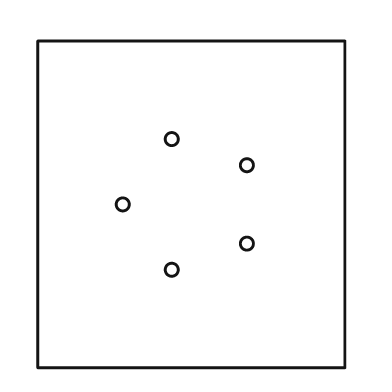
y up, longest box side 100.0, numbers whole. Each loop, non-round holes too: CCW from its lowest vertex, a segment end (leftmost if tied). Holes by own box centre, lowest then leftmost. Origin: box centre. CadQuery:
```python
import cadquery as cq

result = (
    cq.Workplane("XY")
    .moveTo(-47.0, -50.0)
    .lineTo(47.0, -50.0)
    .lineTo(47.0, 50.0)
    .lineTo(-47.0, 50.0)
    .close()
    .moveTo(-6.0, -20.0)
    .circle(2.0)
    .moveTo(17.0, -12.0)
    .circle(2.0)
    .moveTo(-21.0, 0.0)
    .circle(2.0)
    .moveTo(17.0, 12.0)
    .circle(2.0)
    .moveTo(-6.0, 20.0)
    .circle(2.0)
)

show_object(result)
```